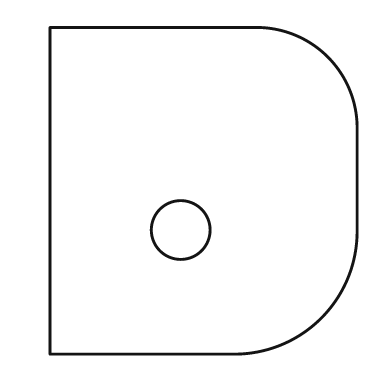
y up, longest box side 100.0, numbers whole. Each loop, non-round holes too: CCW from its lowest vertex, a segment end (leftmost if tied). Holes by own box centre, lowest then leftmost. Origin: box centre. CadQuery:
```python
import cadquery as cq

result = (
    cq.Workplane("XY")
    .moveTo(-47.0, -50.0)
    .lineTo(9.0, -50.0)
    .threePointArc((36.0, -39.0), (47.0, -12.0))
    .lineTo(47.0, 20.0)
    .threePointArc((38.0, 41.0), (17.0, 50.0))
    .lineTo(-47.0, 50.0)
    .close()
    .moveTo(-7.0, -12.0)
    .circle(9.0)
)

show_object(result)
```